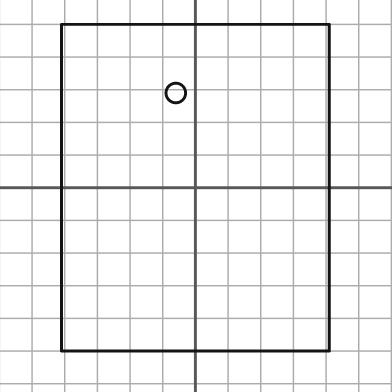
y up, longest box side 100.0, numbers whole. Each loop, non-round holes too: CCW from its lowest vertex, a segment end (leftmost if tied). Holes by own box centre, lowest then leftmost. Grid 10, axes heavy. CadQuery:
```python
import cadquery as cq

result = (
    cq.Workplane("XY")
    .moveTo(-41.0, -50.0)
    .lineTo(41.0, -50.0)
    .lineTo(41.0, 50.0)
    .lineTo(-41.0, 50.0)
    .close()
    .moveTo(-6.0, 29.0)
    .circle(3.0)
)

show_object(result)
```